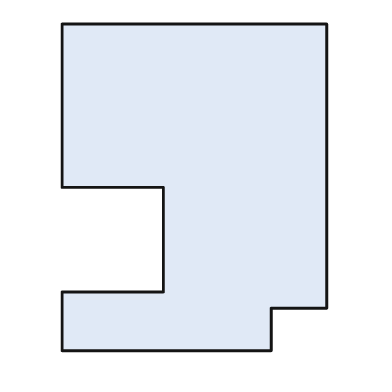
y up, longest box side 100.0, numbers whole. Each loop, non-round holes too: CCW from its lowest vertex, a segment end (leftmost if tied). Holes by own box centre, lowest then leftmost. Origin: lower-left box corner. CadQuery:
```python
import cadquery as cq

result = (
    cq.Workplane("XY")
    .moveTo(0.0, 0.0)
    .lineTo(64.0, 0.0)
    .lineTo(64.0, 13.0)
    .lineTo(81.0, 13.0)
    .lineTo(81.0, 100.0)
    .lineTo(0.0, 100.0)
    .lineTo(0.0, 50.0)
    .lineTo(31.0, 50.0)
    .lineTo(31.0, 18.0)
    .lineTo(0.0, 18.0)
    .close()
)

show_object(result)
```